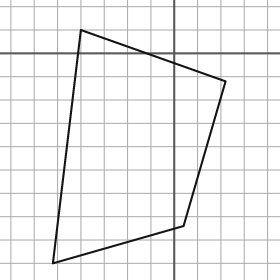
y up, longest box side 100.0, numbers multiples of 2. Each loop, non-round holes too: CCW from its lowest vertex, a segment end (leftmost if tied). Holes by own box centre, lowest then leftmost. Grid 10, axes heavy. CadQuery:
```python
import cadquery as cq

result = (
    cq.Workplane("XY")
    .moveTo(-52.0, -90.0)
    .lineTo(4.0, -74.0)
    .lineTo(22.0, -12.0)
    .lineTo(-40.0, 10.0)
    .close()
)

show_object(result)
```